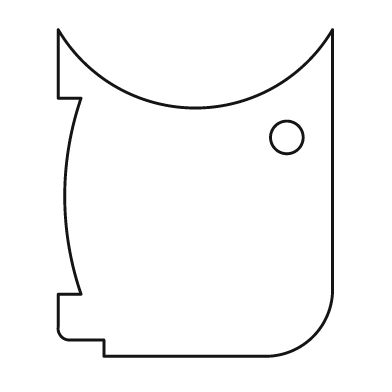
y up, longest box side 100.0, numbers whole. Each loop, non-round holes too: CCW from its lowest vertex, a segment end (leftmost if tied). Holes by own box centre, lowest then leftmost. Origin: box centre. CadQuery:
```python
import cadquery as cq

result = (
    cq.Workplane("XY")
    .moveTo(-28.0, -50.0)
    .lineTo(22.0, -50.0)
    .threePointArc((36.0, -44.0), (42.0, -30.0))
    .lineTo(42.0, 50.0)
    .threePointArc((0.0, 26.0), (-42.0, 50.0))
    .lineTo(-42.0, 29.0)
    .lineTo(-35.0, 29.0)
    .threePointArc((-40.0, -1.0), (-35.0, -31.0))
    .lineTo(-42.0, -31.0)
    .lineTo(-42.0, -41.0)
    .threePointArc((-41.0, -44.0), (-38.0, -45.0))
    .lineTo(-28.0, -45.0)
    .close()
    .moveTo(28.0, 17.0)
    .circle(5.0)
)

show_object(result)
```